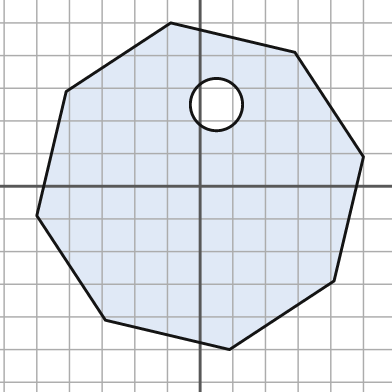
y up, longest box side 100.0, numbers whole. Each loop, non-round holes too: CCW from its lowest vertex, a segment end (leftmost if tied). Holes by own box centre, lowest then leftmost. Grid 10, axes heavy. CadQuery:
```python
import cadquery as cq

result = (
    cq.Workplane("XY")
    .moveTo(9.0, -50.0)
    .lineTo(41.0, -29.0)
    .lineTo(50.0, 9.0)
    .lineTo(29.0, 41.0)
    .lineTo(-9.0, 50.0)
    .lineTo(-41.0, 29.0)
    .lineTo(-50.0, -9.0)
    .lineTo(-29.0, -41.0)
    .close()
    .moveTo(5.0, 25.0)
    .circle(8.0)
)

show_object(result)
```